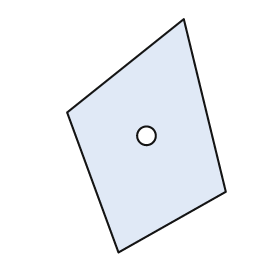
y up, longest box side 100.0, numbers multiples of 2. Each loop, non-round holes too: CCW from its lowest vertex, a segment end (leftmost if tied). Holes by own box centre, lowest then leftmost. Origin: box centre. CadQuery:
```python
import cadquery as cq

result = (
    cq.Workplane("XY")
    .moveTo(-12.0, -50.0)
    .lineTo(34.0, -24.0)
    .lineTo(16.0, 50.0)
    .lineTo(-34.0, 10.0)
    .close()
    .moveTo(0.0, 0.0)
    .circle(4.0)
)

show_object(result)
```